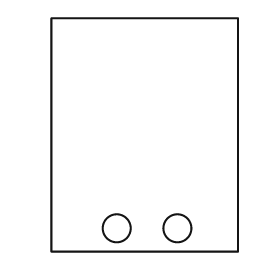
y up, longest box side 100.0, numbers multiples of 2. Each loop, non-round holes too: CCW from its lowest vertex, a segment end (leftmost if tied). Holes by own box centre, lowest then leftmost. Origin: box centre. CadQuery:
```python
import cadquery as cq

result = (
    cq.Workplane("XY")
    .moveTo(-40.0, -50.0)
    .lineTo(40.0, -50.0)
    .lineTo(40.0, 50.0)
    .lineTo(-40.0, 50.0)
    .close()
    .moveTo(-12.0, -40.0)
    .circle(6.0)
    .moveTo(14.0, -40.0)
    .circle(6.0)
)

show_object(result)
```